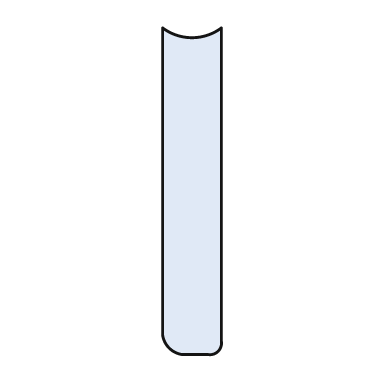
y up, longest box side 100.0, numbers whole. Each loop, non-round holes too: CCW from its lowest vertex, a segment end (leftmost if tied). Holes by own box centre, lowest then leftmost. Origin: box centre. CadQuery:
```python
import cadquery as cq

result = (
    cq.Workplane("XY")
    .moveTo(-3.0, -50.0)
    .lineTo(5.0, -50.0)
    .threePointArc((8.0, -49.0), (9.0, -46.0))
    .lineTo(9.0, 50.0)
    .threePointArc((0.0, 47.0), (-9.0, 50.0))
    .lineTo(-9.0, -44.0)
    .threePointArc((-7.0, -48.0), (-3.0, -50.0))
    .close()
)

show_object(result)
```